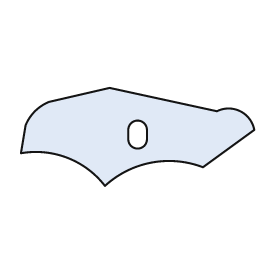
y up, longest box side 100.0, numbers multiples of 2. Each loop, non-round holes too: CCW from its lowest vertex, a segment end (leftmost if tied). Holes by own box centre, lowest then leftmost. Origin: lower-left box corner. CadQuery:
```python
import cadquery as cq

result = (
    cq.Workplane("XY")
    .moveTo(36.0, 0.0)
    .threePointArc((56.0, 10.0), (78.0, 8.0))
    .lineTo(100.0, 24.0)
    .threePointArc((94.0, 32.0), (84.0, 32.0))
    .lineTo(38.0, 42.0)
    .lineTo(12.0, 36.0)
    .threePointArc((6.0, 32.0), (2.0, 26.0))
    .lineTo(0.0, 14.0)
    .threePointArc((20.0, 12.0), (36.0, 0.0))
    .close()
    .moveTo(46.0, 20.0)
    .threePointArc((50.0, 16.0), (54.0, 20.0))
    .lineTo(54.0, 24.0)
    .threePointArc((50.0, 28.0), (46.0, 24.0))
    .close()
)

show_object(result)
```